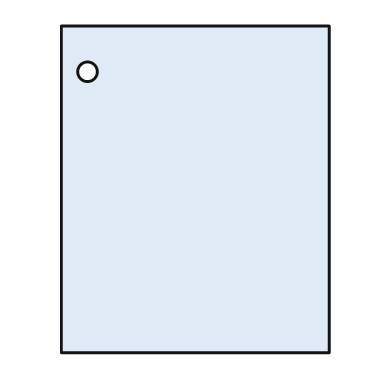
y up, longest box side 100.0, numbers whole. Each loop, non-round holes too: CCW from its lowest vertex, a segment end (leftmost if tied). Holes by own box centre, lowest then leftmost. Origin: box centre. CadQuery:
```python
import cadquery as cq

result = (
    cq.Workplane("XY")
    .moveTo(-41.0, -50.0)
    .lineTo(41.0, -50.0)
    .lineTo(41.0, 50.0)
    .lineTo(-41.0, 50.0)
    .close()
    .moveTo(-33.0, 36.0)
    .circle(3.0)
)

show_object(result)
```